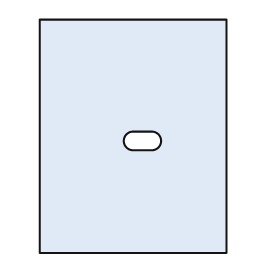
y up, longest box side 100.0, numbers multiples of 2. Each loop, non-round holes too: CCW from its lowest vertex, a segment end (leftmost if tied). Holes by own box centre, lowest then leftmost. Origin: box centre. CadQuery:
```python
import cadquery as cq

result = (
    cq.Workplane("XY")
    .moveTo(-40.0, -50.0)
    .lineTo(40.0, -50.0)
    .lineTo(40.0, 50.0)
    .lineTo(-40.0, 50.0)
    .close()
    .moveTo(0.0, -6.0)
    .lineTo(8.0, -6.0)
    .threePointArc((12.0, -2.0), (8.0, 2.0))
    .lineTo(0.0, 2.0)
    .threePointArc((-4.0, -2.0), (0.0, -6.0))
    .close()
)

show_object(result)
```